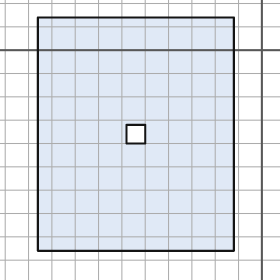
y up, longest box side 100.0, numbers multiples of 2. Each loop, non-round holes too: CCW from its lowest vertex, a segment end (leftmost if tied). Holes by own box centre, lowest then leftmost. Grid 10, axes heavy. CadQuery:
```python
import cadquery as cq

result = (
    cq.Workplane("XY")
    .moveTo(-96.0, -86.0)
    .lineTo(-12.0, -86.0)
    .lineTo(-12.0, 14.0)
    .lineTo(-96.0, 14.0)
    .close()
    .moveTo(-58.0, -40.0)
    .lineTo(-50.0, -40.0)
    .lineTo(-50.0, -32.0)
    .lineTo(-58.0, -32.0)
    .close()
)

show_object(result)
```